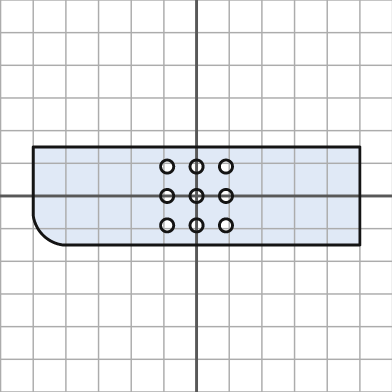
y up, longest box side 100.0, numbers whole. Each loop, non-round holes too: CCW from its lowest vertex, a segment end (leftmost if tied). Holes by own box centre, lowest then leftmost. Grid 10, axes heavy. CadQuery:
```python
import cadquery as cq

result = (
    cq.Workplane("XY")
    .moveTo(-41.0, -15.0)
    .lineTo(50.0, -15.0)
    .lineTo(50.0, 15.0)
    .lineTo(-50.0, 15.0)
    .lineTo(-50.0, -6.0)
    .threePointArc((-47.0, -12.0), (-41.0, -15.0))
    .close()
    .moveTo(-9.0, -9.0)
    .circle(2.0)
    .moveTo(0.0, -9.0)
    .circle(2.0)
    .moveTo(9.0, -9.0)
    .circle(2.0)
    .moveTo(-9.0, 0.0)
    .circle(2.0)
    .moveTo(0.0, 0.0)
    .circle(2.0)
    .moveTo(9.0, 0.0)
    .circle(2.0)
    .moveTo(-9.0, 9.0)
    .circle(2.0)
    .moveTo(0.0, 9.0)
    .circle(2.0)
    .moveTo(9.0, 9.0)
    .circle(2.0)
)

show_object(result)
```